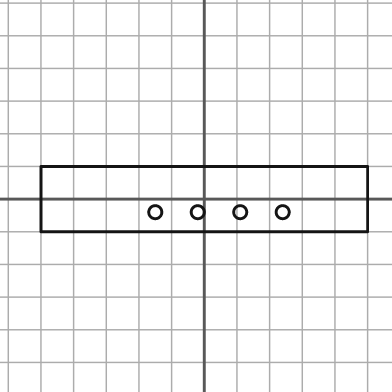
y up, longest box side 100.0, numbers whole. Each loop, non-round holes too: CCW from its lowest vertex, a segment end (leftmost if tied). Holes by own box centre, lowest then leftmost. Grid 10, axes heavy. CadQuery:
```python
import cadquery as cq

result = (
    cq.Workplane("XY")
    .moveTo(-50.0, -10.0)
    .lineTo(50.0, -10.0)
    .lineTo(50.0, 10.0)
    .lineTo(-50.0, 10.0)
    .close()
    .moveTo(-15.0, -4.0)
    .circle(2.0)
    .moveTo(-2.0, -4.0)
    .circle(2.0)
    .moveTo(11.0, -4.0)
    .circle(2.0)
    .moveTo(24.0, -4.0)
    .circle(2.0)
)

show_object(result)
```